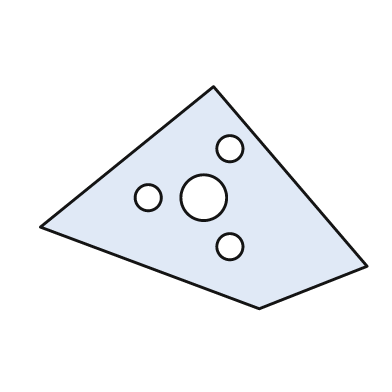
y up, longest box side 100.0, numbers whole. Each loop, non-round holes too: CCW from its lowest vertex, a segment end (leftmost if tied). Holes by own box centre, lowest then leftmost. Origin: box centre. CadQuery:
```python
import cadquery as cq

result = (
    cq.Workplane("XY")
    .moveTo(17.0, -34.0)
    .lineTo(50.0, -21.0)
    .lineTo(3.0, 34.0)
    .lineTo(-50.0, -9.0)
    .close()
    .moveTo(8.0, -15.0)
    .circle(4.0)
    .moveTo(-17.0, 0.0)
    .circle(4.0)
    .moveTo(0.0, 0.0)
    .circle(7.0)
    .moveTo(8.0, 15.0)
    .circle(4.0)
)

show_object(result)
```